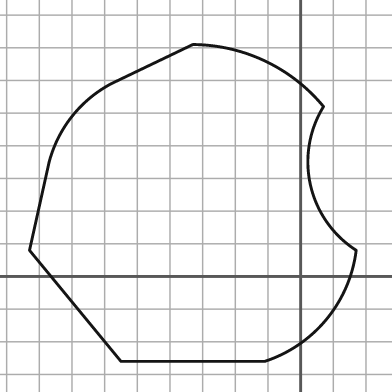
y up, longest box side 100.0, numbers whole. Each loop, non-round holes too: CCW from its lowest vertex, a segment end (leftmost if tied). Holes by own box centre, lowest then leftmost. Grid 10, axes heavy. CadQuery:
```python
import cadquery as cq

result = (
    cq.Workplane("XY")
    .moveTo(-55.0, -26.0)
    .lineTo(-11.0, -26.0)
    .threePointArc((8.0, -13.0), (17.0, 8.0))
    .threePointArc((3.0, 28.0), (7.0, 52.0))
    .threePointArc((-11.0, 66.0), (-33.0, 71.0))
    .lineTo(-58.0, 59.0)
    .threePointArc((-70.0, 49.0), (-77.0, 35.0))
    .lineTo(-83.0, 8.0)
    .close()
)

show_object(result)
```